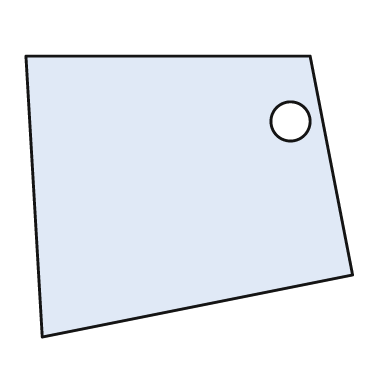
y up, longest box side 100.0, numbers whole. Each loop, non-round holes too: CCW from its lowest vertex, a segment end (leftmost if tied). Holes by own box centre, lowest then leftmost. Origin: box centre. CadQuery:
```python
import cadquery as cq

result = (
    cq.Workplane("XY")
    .moveTo(-45.0, -43.0)
    .lineTo(50.0, -24.0)
    .lineTo(37.0, 43.0)
    .lineTo(-50.0, 43.0)
    .close()
    .moveTo(31.0, 23.0)
    .circle(6.0)
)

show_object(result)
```